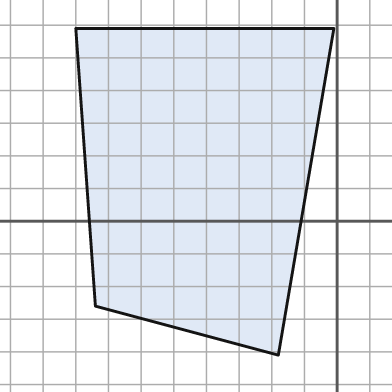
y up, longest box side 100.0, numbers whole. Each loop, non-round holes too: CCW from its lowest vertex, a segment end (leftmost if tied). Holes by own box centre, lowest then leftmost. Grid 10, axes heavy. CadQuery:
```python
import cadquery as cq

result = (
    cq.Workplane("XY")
    .moveTo(-18.0, -41.0)
    .lineTo(-1.0, 59.0)
    .lineTo(-80.0, 59.0)
    .lineTo(-74.0, -26.0)
    .close()
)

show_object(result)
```